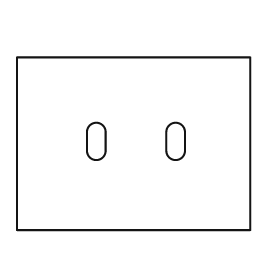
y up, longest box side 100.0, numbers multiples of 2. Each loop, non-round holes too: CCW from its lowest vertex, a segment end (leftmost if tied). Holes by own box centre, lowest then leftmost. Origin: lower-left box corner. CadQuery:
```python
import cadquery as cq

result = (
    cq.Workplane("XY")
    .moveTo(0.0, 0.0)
    .lineTo(100.0, 0.0)
    .lineTo(100.0, 74.0)
    .lineTo(0.0, 74.0)
    .close()
    .moveTo(30.0, 34.0)
    .threePointArc((34.0, 30.0), (38.0, 34.0))
    .lineTo(38.0, 42.0)
    .threePointArc((34.0, 46.0), (30.0, 42.0))
    .close()
    .moveTo(64.0, 34.0)
    .threePointArc((68.0, 30.0), (72.0, 34.0))
    .lineTo(72.0, 42.0)
    .threePointArc((68.0, 46.0), (64.0, 42.0))
    .close()
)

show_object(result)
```